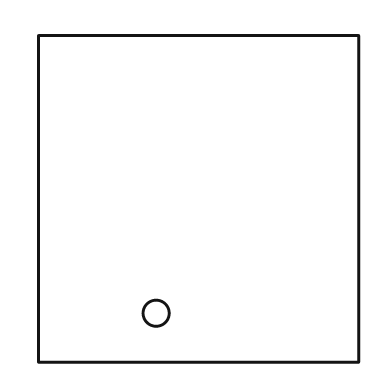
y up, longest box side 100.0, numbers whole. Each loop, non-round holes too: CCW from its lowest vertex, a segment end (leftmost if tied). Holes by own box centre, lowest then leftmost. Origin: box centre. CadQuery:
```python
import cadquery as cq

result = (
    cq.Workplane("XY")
    .moveTo(-49.0, -50.0)
    .lineTo(49.0, -50.0)
    .lineTo(49.0, 50.0)
    .lineTo(-49.0, 50.0)
    .close()
    .moveTo(-13.0, -35.0)
    .circle(4.0)
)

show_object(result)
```